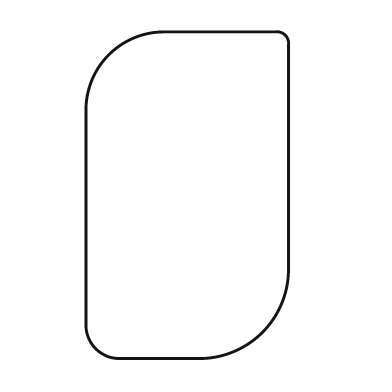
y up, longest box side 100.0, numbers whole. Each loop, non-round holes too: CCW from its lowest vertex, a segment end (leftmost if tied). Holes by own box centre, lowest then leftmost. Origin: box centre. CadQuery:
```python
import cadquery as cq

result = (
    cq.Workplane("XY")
    .moveTo(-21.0, -50.0)
    .lineTo(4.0, -50.0)
    .threePointArc((23.0, -42.0), (31.0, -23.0))
    .lineTo(31.0, 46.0)
    .threePointArc((30.0, 49.0), (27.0, 50.0))
    .lineTo(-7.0, 50.0)
    .threePointArc((-24.0, 43.0), (-31.0, 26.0))
    .lineTo(-31.0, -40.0)
    .threePointArc((-28.0, -47.0), (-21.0, -50.0))
    .close()
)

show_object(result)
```